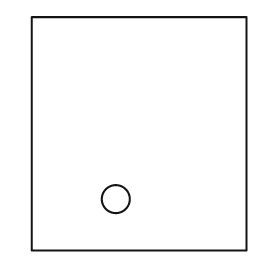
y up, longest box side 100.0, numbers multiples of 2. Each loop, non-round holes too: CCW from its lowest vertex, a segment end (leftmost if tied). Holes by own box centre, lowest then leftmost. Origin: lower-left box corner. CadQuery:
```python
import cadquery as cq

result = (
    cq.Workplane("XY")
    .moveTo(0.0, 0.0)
    .lineTo(92.0, 0.0)
    .lineTo(92.0, 100.0)
    .lineTo(0.0, 100.0)
    .close()
    .moveTo(36.0, 22.0)
    .circle(6.0)
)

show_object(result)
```